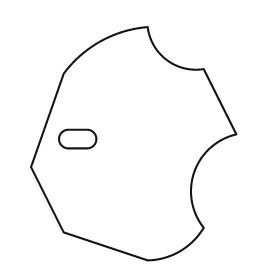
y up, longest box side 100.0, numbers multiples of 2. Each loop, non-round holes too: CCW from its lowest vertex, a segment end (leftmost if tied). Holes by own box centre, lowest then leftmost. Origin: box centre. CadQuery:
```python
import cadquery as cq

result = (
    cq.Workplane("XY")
    .moveTo(6.0, -50.0)
    .threePointArc((20.0, -46.0), (30.0, -36.0))
    .threePointArc((26.0, -12.0), (44.0, 4.0))
    .lineTo(30.0, 32.0)
    .threePointArc((14.0, 36.0), (6.0, 50.0))
    .threePointArc((-14.0, 44.0), (-30.0, 30.0))
    .lineTo(-44.0, -10.0)
    .lineTo(-30.0, -38.0)
    .close()
    .moveTo(-28.0, -2.0)
    .lineTo(-20.0, -2.0)
    .threePointArc((-16.0, 2.0), (-20.0, 6.0))
    .lineTo(-28.0, 6.0)
    .threePointArc((-32.0, 2.0), (-28.0, -2.0))
    .close()
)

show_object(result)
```